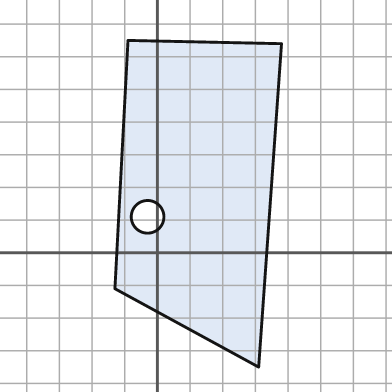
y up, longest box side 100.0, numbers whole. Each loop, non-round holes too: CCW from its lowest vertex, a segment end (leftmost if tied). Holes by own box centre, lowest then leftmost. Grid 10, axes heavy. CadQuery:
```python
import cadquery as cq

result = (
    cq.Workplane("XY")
    .moveTo(31.0, -35.0)
    .lineTo(38.0, 64.0)
    .lineTo(-9.0, 65.0)
    .lineTo(-13.0, -11.0)
    .close()
    .moveTo(-3.0, 11.0)
    .circle(5.0)
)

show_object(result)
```